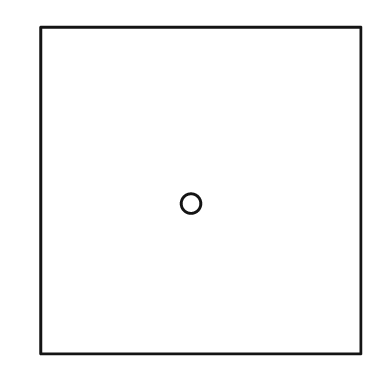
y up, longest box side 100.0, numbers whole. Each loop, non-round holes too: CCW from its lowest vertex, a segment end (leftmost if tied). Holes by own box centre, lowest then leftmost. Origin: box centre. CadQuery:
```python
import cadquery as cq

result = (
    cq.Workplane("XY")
    .moveTo(-49.0, -50.0)
    .lineTo(49.0, -50.0)
    .lineTo(49.0, 50.0)
    .lineTo(-49.0, 50.0)
    .close()
    .moveTo(-3.0, -4.0)
    .circle(3.0)
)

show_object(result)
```